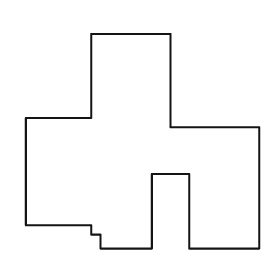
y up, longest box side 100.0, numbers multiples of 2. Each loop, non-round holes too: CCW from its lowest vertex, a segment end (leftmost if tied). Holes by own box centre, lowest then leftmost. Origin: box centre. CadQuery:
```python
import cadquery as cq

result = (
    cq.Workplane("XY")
    .moveTo(-18.0, -46.0)
    .lineTo(4.0, -46.0)
    .lineTo(4.0, -14.0)
    .lineTo(20.0, -14.0)
    .lineTo(20.0, -46.0)
    .lineTo(50.0, -46.0)
    .lineTo(50.0, 6.0)
    .lineTo(12.0, 6.0)
    .lineTo(12.0, 46.0)
    .lineTo(-22.0, 46.0)
    .lineTo(-22.0, 10.0)
    .lineTo(-50.0, 10.0)
    .lineTo(-50.0, -36.0)
    .lineTo(-22.0, -36.0)
    .lineTo(-22.0, -40.0)
    .lineTo(-18.0, -40.0)
    .close()
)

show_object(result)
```